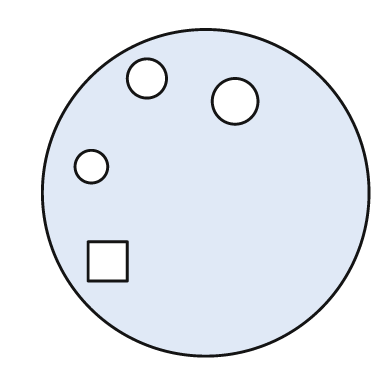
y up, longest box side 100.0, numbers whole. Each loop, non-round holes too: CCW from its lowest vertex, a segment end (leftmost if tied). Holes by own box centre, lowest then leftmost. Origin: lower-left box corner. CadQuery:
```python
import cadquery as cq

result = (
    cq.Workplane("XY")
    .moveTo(50.0, 50.0)
    .circle(50.0)
    .moveTo(14.0, 23.0)
    .lineTo(26.0, 23.0)
    .lineTo(26.0, 35.0)
    .lineTo(14.0, 35.0)
    .close()
    .moveTo(15.0, 58.0)
    .circle(5.0)
    .moveTo(59.0, 78.0)
    .circle(7.0)
    .moveTo(32.0, 85.0)
    .circle(6.0)
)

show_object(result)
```